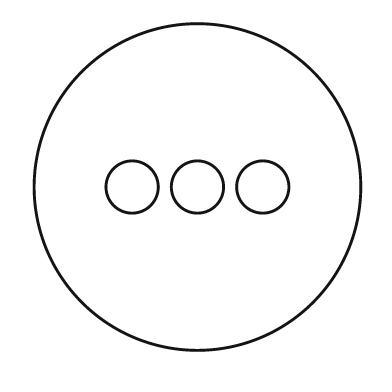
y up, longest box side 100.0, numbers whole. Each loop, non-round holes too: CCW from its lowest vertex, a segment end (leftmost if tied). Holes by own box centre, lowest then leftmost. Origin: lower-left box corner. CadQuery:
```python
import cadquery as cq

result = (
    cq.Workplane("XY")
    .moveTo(50.0, 50.0)
    .circle(50.0)
    .moveTo(30.0, 50.0)
    .circle(8.0)
    .moveTo(50.0, 50.0)
    .circle(8.0)
    .moveTo(70.0, 50.0)
    .circle(8.0)
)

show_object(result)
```